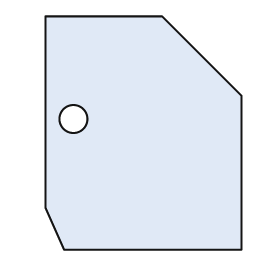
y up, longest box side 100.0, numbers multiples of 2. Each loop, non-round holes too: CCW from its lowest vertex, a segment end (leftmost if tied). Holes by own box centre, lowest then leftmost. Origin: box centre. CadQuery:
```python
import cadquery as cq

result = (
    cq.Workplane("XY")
    .moveTo(-34.0, -50.0)
    .lineTo(42.0, -50.0)
    .lineTo(42.0, 16.0)
    .lineTo(8.0, 50.0)
    .lineTo(-42.0, 50.0)
    .lineTo(-42.0, -32.0)
    .close()
    .moveTo(-30.0, 6.0)
    .circle(6.0)
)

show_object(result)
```